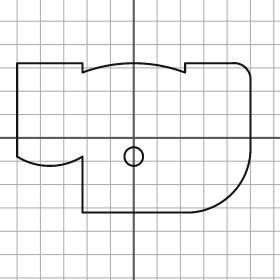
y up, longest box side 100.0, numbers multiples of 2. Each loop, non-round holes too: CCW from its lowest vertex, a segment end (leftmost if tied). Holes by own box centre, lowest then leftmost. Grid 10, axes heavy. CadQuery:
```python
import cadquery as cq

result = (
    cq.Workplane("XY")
    .moveTo(-22.0, -32.0)
    .lineTo(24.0, -32.0)
    .threePointArc((42.0, -24.0), (50.0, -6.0))
    .lineTo(50.0, 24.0)
    .threePointArc((48.0, 30.0), (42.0, 32.0))
    .lineTo(22.0, 32.0)
    .lineTo(22.0, 28.0)
    .threePointArc((0.0, 32.0), (-22.0, 28.0))
    .lineTo(-22.0, 32.0)
    .lineTo(-50.0, 32.0)
    .lineTo(-50.0, -8.0)
    .threePointArc((-36.0, -12.0), (-22.0, -8.0))
    .close()
    .moveTo(0.0, -8.0)
    .circle(4.0)
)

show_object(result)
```